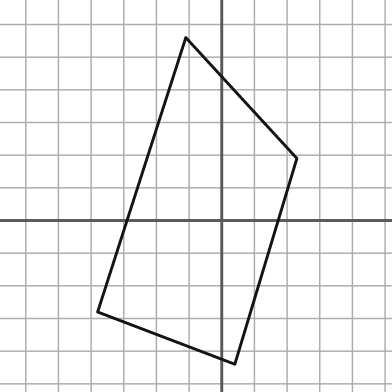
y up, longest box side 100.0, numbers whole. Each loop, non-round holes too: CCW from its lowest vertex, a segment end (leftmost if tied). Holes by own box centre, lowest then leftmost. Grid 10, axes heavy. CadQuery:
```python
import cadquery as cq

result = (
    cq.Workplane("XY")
    .moveTo(4.0, -44.0)
    .lineTo(23.0, 19.0)
    .lineTo(-11.0, 56.0)
    .lineTo(-38.0, -28.0)
    .close()
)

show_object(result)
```